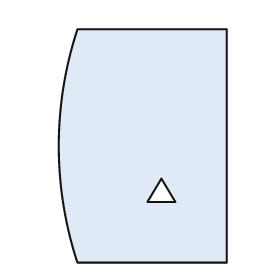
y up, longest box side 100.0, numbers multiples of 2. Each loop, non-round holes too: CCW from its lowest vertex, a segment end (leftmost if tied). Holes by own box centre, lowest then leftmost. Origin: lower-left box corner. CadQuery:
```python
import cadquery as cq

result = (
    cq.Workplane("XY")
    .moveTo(8.0, 0.0)
    .lineTo(72.0, 0.0)
    .lineTo(72.0, 100.0)
    .lineTo(8.0, 100.0)
    .threePointArc((0.0, 50.0), (8.0, 0.0))
    .close()
    .moveTo(38.0, 26.0)
    .lineTo(50.0, 26.0)
    .lineTo(44.0, 36.0)
    .close()
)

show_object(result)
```